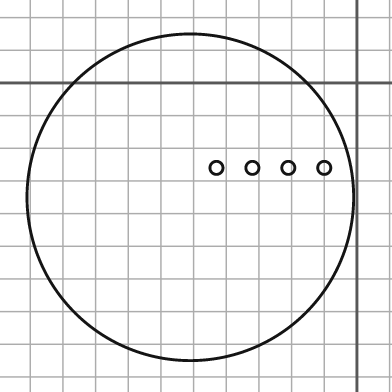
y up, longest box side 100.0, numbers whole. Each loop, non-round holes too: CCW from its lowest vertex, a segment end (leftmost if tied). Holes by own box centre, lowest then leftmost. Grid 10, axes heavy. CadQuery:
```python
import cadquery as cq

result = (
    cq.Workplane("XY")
    .moveTo(-51.0, -35.0)
    .circle(50.0)
    .moveTo(-43.0, -26.0)
    .circle(2.0)
    .moveTo(-32.0, -26.0)
    .circle(2.0)
    .moveTo(-21.0, -26.0)
    .circle(2.0)
    .moveTo(-10.0, -26.0)
    .circle(2.0)
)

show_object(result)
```